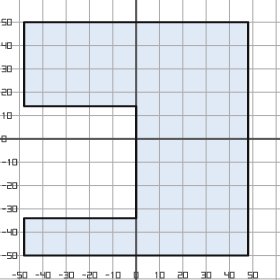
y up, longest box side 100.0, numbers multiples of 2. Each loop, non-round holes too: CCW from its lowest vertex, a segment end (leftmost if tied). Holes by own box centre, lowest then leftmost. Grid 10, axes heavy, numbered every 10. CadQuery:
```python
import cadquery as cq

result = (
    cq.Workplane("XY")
    .moveTo(-48.0, -50.0)
    .lineTo(48.0, -50.0)
    .lineTo(48.0, 50.0)
    .lineTo(-48.0, 50.0)
    .lineTo(-48.0, 14.0)
    .lineTo(0.0, 14.0)
    .lineTo(0.0, -34.0)
    .lineTo(-48.0, -34.0)
    .close()
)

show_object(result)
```